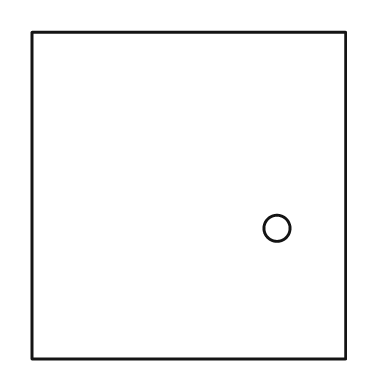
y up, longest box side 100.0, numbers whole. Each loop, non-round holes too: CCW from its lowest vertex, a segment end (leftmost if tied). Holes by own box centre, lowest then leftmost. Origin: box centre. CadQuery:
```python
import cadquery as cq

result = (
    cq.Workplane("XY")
    .moveTo(-48.0, -50.0)
    .lineTo(48.0, -50.0)
    .lineTo(48.0, 50.0)
    .lineTo(-48.0, 50.0)
    .close()
    .moveTo(27.0, -10.0)
    .circle(4.0)
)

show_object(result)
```